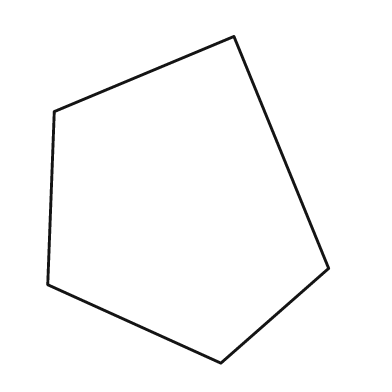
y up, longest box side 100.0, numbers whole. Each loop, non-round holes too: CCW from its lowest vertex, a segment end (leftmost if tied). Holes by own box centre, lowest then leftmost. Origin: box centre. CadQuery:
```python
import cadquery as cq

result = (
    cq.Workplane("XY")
    .moveTo(10.0, -50.0)
    .lineTo(43.0, -21.0)
    .lineTo(14.0, 50.0)
    .lineTo(-41.0, 27.0)
    .lineTo(-43.0, -26.0)
    .close()
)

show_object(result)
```